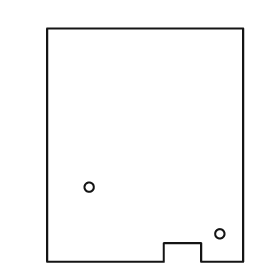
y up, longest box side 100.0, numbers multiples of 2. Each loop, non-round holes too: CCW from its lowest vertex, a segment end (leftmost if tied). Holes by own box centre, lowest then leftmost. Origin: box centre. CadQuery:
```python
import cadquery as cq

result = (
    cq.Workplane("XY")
    .moveTo(-42.0, -50.0)
    .lineTo(8.0, -50.0)
    .lineTo(8.0, -42.0)
    .lineTo(24.0, -42.0)
    .lineTo(24.0, -50.0)
    .lineTo(42.0, -50.0)
    .lineTo(42.0, 50.0)
    .lineTo(-42.0, 50.0)
    .close()
    .moveTo(32.0, -38.0)
    .circle(2.0)
    .moveTo(-24.0, -18.0)
    .circle(2.0)
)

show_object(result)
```